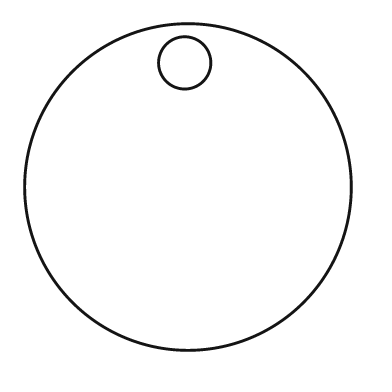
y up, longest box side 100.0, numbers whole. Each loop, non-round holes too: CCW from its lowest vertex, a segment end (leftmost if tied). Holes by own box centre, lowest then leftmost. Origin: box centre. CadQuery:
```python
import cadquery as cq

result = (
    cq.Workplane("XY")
    .moveTo(0.0, 0.0)
    .circle(50.0)
    .moveTo(-1.0, 38.0)
    .circle(8.0)
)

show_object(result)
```